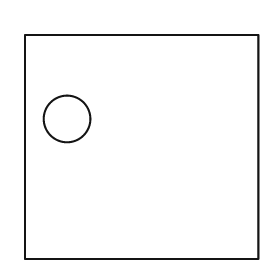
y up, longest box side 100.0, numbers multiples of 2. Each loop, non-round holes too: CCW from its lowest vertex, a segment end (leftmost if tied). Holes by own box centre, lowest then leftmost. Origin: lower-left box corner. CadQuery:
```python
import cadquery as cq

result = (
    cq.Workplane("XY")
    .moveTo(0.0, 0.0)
    .lineTo(100.0, 0.0)
    .lineTo(100.0, 96.0)
    .lineTo(0.0, 96.0)
    .close()
    .moveTo(18.0, 60.0)
    .circle(10.0)
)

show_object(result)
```